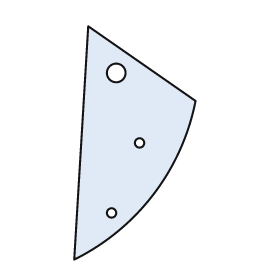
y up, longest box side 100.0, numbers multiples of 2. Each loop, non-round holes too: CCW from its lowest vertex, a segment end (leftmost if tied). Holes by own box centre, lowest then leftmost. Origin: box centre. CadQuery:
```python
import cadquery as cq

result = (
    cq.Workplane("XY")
    .moveTo(-26.0, -50.0)
    .threePointArc((8.0, -22.0), (26.0, 18.0))
    .lineTo(-20.0, 50.0)
    .close()
    .moveTo(-10.0, -30.0)
    .circle(2.0)
    .moveTo(2.0, 0.0)
    .circle(2.0)
    .moveTo(-8.0, 30.0)
    .circle(4.0)
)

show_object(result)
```